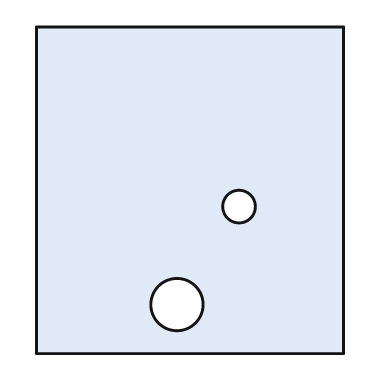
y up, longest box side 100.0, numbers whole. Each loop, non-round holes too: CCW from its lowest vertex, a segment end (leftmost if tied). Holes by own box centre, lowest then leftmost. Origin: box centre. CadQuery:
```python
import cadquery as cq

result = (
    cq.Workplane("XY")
    .moveTo(-47.0, -50.0)
    .lineTo(47.0, -50.0)
    .lineTo(47.0, 50.0)
    .lineTo(-47.0, 50.0)
    .close()
    .moveTo(-4.0, -35.0)
    .circle(8.0)
    .moveTo(15.0, -5.0)
    .circle(5.0)
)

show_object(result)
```